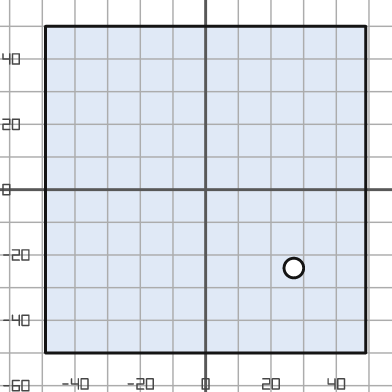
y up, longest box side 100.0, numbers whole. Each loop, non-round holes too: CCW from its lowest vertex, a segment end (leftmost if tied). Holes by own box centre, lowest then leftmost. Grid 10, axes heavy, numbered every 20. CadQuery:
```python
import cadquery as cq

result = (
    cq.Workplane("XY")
    .moveTo(-49.0, -50.0)
    .lineTo(49.0, -50.0)
    .lineTo(49.0, 50.0)
    .lineTo(-49.0, 50.0)
    .close()
    .moveTo(27.0, -24.0)
    .circle(3.0)
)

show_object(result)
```